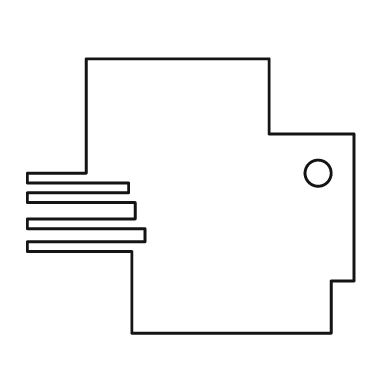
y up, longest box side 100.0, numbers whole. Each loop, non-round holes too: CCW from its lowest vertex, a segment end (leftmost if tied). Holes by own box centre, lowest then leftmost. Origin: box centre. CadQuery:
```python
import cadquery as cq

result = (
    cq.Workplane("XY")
    .moveTo(-18.0, -42.0)
    .lineTo(43.0, -42.0)
    .lineTo(43.0, -26.0)
    .lineTo(50.0, -26.0)
    .lineTo(50.0, 19.0)
    .lineTo(24.0, 19.0)
    .lineTo(24.0, 42.0)
    .lineTo(-32.0, 42.0)
    .lineTo(-32.0, 7.0)
    .lineTo(-50.0, 7.0)
    .lineTo(-50.0, 4.0)
    .lineTo(-19.0, 4.0)
    .lineTo(-19.0, 1.0)
    .lineTo(-50.0, 1.0)
    .lineTo(-50.0, -2.0)
    .lineTo(-17.0, -2.0)
    .lineTo(-17.0, -7.0)
    .lineTo(-50.0, -7.0)
    .lineTo(-50.0, -10.0)
    .lineTo(-14.0, -10.0)
    .lineTo(-14.0, -14.0)
    .lineTo(-50.0, -14.0)
    .lineTo(-50.0, -17.0)
    .lineTo(-18.0, -17.0)
    .close()
    .moveTo(39.0, 7.0)
    .circle(4.0)
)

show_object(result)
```